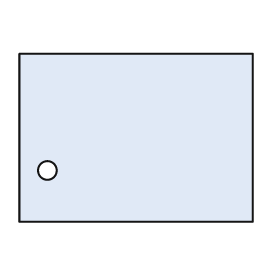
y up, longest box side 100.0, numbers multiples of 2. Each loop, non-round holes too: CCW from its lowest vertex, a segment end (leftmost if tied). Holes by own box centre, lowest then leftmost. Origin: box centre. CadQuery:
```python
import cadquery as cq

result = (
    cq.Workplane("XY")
    .moveTo(-50.0, -36.0)
    .lineTo(50.0, -36.0)
    .lineTo(50.0, 36.0)
    .lineTo(-50.0, 36.0)
    .close()
    .moveTo(-38.0, -14.0)
    .circle(4.0)
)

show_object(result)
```